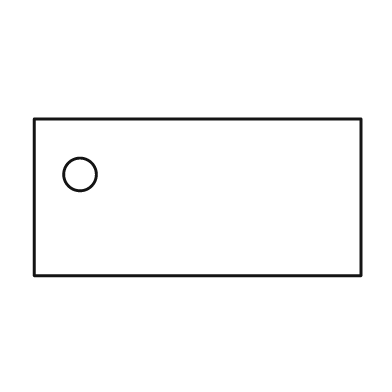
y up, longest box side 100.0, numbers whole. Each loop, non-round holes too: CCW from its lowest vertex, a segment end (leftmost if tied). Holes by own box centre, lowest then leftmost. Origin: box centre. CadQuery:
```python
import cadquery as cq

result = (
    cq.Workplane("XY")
    .moveTo(-50.0, -24.0)
    .lineTo(50.0, -24.0)
    .lineTo(50.0, 24.0)
    .lineTo(-50.0, 24.0)
    .close()
    .moveTo(-36.0, 7.0)
    .circle(5.0)
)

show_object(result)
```